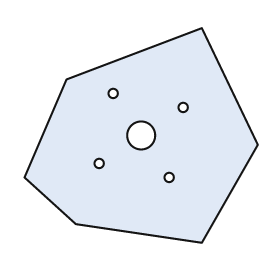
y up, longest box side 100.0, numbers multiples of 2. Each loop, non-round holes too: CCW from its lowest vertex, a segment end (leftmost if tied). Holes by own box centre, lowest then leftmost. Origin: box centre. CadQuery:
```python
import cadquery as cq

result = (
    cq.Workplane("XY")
    .moveTo(26.0, -46.0)
    .lineTo(50.0, -4.0)
    .lineTo(26.0, 46.0)
    .lineTo(-32.0, 24.0)
    .lineTo(-50.0, -18.0)
    .lineTo(-28.0, -38.0)
    .close()
    .moveTo(12.0, -18.0)
    .circle(2.0)
    .moveTo(-18.0, -12.0)
    .circle(2.0)
    .moveTo(0.0, 0.0)
    .circle(6.0)
    .moveTo(18.0, 12.0)
    .circle(2.0)
    .moveTo(-12.0, 18.0)
    .circle(2.0)
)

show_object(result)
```